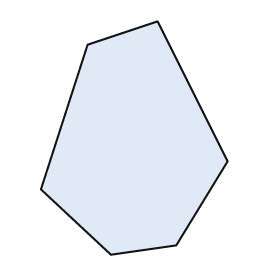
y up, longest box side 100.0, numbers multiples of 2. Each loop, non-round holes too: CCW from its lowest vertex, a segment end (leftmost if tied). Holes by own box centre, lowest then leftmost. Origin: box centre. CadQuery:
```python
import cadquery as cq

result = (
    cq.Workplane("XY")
    .moveTo(-10.0, -50.0)
    .lineTo(18.0, -46.0)
    .lineTo(40.0, -10.0)
    .lineTo(10.0, 50.0)
    .lineTo(-20.0, 40.0)
    .lineTo(-40.0, -22.0)
    .close()
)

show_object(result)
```